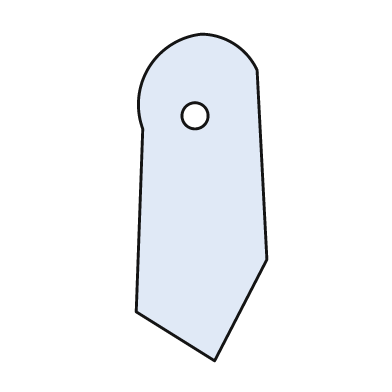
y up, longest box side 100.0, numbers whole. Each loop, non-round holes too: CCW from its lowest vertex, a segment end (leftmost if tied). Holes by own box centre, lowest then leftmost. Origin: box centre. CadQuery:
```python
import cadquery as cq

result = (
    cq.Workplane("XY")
    .moveTo(4.0, -50.0)
    .lineTo(20.0, -19.0)
    .lineTo(17.0, 39.0)
    .threePointArc((10.0, 47.0), (0.0, 50.0))
    .threePointArc((-16.0, 40.0), (-18.0, 21.0))
    .lineTo(-20.0, -35.0)
    .close()
    .moveTo(-2.0, 25.0)
    .circle(4.0)
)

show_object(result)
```